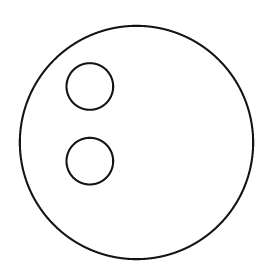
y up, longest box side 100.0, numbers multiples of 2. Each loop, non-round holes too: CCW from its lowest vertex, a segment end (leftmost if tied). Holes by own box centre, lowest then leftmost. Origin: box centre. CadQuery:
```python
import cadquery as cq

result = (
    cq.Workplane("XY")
    .moveTo(0.0, 0.0)
    .circle(50.0)
    .moveTo(-20.0, -8.0)
    .circle(10.0)
    .moveTo(-20.0, 24.0)
    .circle(10.0)
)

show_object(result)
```